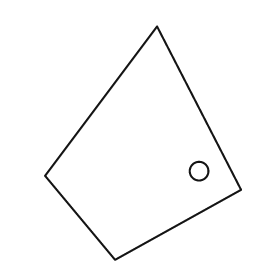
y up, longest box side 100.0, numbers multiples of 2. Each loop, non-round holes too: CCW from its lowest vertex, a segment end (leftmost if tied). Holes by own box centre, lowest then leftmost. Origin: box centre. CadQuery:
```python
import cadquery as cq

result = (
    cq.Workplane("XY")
    .moveTo(-12.0, -50.0)
    .lineTo(42.0, -20.0)
    .lineTo(6.0, 50.0)
    .lineTo(-42.0, -14.0)
    .close()
    .moveTo(24.0, -12.0)
    .circle(4.0)
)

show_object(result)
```